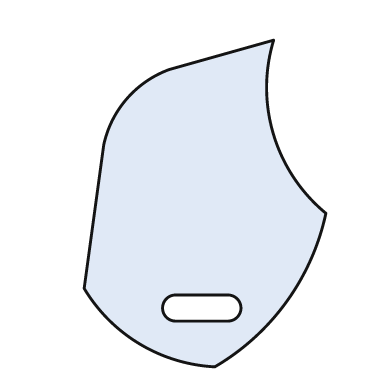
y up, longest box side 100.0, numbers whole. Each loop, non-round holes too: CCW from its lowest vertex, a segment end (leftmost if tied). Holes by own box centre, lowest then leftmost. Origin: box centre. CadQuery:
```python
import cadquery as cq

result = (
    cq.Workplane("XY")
    .moveTo(3.0, -50.0)
    .threePointArc((25.0, -30.0), (37.0, -3.0))
    .threePointArc((21.0, 21.0), (21.0, 50.0))
    .lineTo(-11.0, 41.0)
    .threePointArc((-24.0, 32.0), (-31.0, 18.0))
    .lineTo(-37.0, -26.0)
    .threePointArc((-20.0, -43.0), (3.0, -50.0))
    .close()
    .moveTo(-9.0, -36.0)
    .lineTo(7.0, -36.0)
    .threePointArc((11.0, -32.0), (7.0, -28.0))
    .lineTo(-9.0, -28.0)
    .threePointArc((-13.0, -32.0), (-9.0, -36.0))
    .close()
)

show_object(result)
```